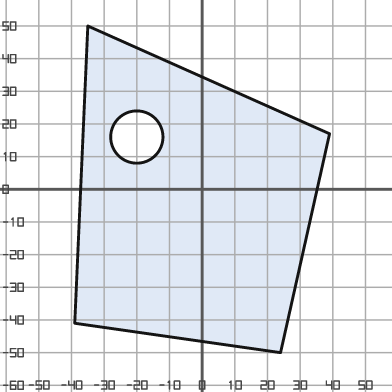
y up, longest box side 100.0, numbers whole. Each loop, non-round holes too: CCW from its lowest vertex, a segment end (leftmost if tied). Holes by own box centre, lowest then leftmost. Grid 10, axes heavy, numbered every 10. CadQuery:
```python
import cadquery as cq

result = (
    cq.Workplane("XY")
    .moveTo(24.0, -50.0)
    .lineTo(39.0, 17.0)
    .lineTo(-35.0, 50.0)
    .lineTo(-39.0, -41.0)
    .close()
    .moveTo(-20.0, 16.0)
    .circle(8.0)
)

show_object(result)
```